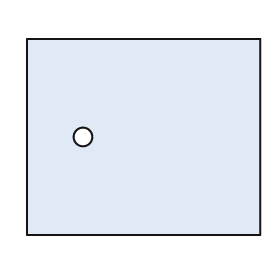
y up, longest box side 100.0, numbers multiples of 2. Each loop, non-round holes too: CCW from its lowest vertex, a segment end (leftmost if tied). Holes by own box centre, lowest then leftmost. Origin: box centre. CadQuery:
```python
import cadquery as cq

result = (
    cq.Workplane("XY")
    .moveTo(-50.0, -42.0)
    .lineTo(50.0, -42.0)
    .lineTo(50.0, 42.0)
    .lineTo(-50.0, 42.0)
    .close()
    .moveTo(-26.0, 0.0)
    .circle(4.0)
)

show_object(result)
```